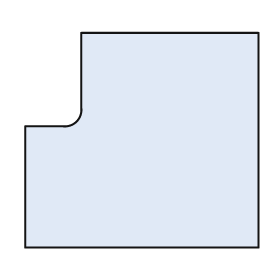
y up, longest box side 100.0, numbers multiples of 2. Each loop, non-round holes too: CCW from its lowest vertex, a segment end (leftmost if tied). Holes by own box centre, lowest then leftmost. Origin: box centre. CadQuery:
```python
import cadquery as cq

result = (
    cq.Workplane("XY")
    .moveTo(-50.0, -46.0)
    .lineTo(50.0, -46.0)
    .lineTo(50.0, 46.0)
    .lineTo(-26.0, 46.0)
    .lineTo(-26.0, 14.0)
    .threePointArc((-28.0, 8.0), (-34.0, 6.0))
    .lineTo(-50.0, 6.0)
    .close()
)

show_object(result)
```